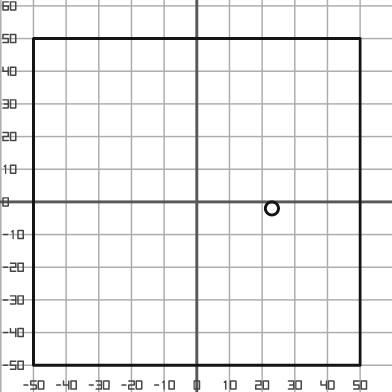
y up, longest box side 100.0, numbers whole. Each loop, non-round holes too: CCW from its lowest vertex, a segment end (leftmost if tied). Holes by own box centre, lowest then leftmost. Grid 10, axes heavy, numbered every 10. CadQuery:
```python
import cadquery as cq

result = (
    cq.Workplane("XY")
    .moveTo(-50.0, -50.0)
    .lineTo(50.0, -50.0)
    .lineTo(50.0, 50.0)
    .lineTo(-50.0, 50.0)
    .close()
    .moveTo(23.0, -2.0)
    .circle(2.0)
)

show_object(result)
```